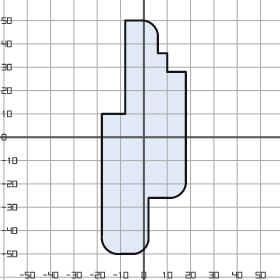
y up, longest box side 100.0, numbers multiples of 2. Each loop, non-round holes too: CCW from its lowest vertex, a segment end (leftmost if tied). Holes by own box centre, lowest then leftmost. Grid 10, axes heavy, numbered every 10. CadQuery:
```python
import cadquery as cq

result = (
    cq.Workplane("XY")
    .moveTo(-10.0, -50.0)
    .lineTo(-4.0, -50.0)
    .threePointArc((0.0, -48.0), (2.0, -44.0))
    .lineTo(2.0, -26.0)
    .lineTo(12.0, -26.0)
    .threePointArc((16.0, -24.0), (18.0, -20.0))
    .lineTo(18.0, 28.0)
    .lineTo(10.0, 28.0)
    .lineTo(10.0, 36.0)
    .lineTo(6.0, 36.0)
    .lineTo(6.0, 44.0)
    .threePointArc((4.0, 48.0), (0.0, 50.0))
    .lineTo(-8.0, 50.0)
    .lineTo(-8.0, 10.0)
    .lineTo(-18.0, 10.0)
    .lineTo(-18.0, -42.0)
    .threePointArc((-16.0, -48.0), (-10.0, -50.0))
    .close()
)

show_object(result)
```